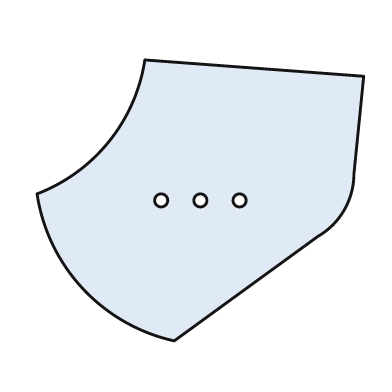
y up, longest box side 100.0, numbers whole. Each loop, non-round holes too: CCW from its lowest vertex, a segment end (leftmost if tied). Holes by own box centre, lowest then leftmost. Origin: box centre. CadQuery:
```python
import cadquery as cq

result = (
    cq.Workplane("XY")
    .moveTo(-8.0, -43.0)
    .lineTo(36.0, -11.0)
    .threePointArc((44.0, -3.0), (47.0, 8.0))
    .lineTo(50.0, 38.0)
    .lineTo(-17.0, 43.0)
    .threePointArc((-28.0, 18.0), (-50.0, 2.0))
    .threePointArc((-36.0, -27.0), (-8.0, -43.0))
    .close()
    .moveTo(-12.0, 0.0)
    .circle(2.0)
    .moveTo(0.0, 0.0)
    .circle(2.0)
    .moveTo(12.0, 0.0)
    .circle(2.0)
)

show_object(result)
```